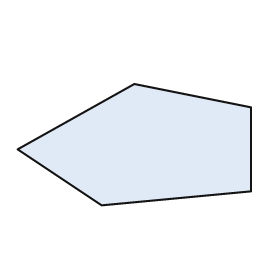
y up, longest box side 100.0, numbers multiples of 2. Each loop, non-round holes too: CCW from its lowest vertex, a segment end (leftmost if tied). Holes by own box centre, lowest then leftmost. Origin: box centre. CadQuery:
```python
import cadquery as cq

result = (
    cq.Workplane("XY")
    .moveTo(-14.0, -26.0)
    .lineTo(50.0, -20.0)
    .lineTo(50.0, 16.0)
    .lineTo(0.0, 26.0)
    .lineTo(-50.0, -2.0)
    .close()
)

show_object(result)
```